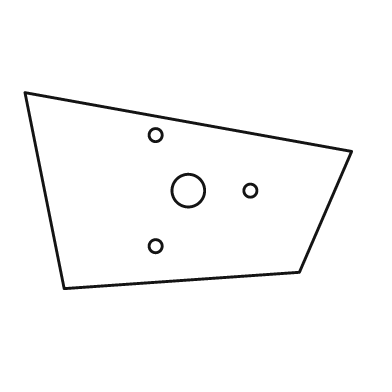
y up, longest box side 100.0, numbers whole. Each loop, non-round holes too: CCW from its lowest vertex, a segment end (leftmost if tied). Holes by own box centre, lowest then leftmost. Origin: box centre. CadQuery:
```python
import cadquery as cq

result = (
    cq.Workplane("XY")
    .moveTo(-38.0, -30.0)
    .lineTo(34.0, -25.0)
    .lineTo(50.0, 12.0)
    .lineTo(-50.0, 30.0)
    .close()
    .moveTo(-10.0, -17.0)
    .circle(2.0)
    .moveTo(0.0, 0.0)
    .circle(5.0)
    .moveTo(19.0, 0.0)
    .circle(2.0)
    .moveTo(-10.0, 17.0)
    .circle(2.0)
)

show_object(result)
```